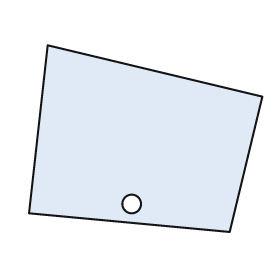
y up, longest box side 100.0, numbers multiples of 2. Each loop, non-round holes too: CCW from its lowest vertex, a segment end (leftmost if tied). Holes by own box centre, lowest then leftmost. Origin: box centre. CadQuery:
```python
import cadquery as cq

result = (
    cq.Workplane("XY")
    .moveTo(36.0, -40.0)
    .lineTo(50.0, 18.0)
    .lineTo(-42.0, 40.0)
    .lineTo(-50.0, -32.0)
    .close()
    .moveTo(-6.0, -28.0)
    .circle(4.0)
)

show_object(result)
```